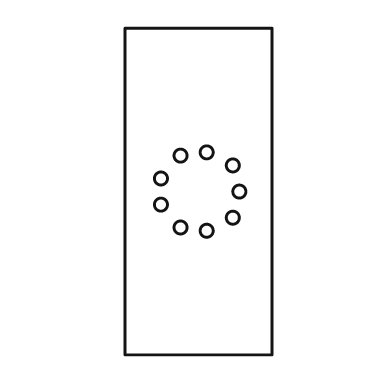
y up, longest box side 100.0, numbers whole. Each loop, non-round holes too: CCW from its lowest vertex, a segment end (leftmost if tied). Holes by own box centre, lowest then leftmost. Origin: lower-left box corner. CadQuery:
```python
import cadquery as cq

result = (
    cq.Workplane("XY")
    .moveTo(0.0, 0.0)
    .lineTo(45.0, 0.0)
    .lineTo(45.0, 100.0)
    .lineTo(0.0, 100.0)
    .close()
    .moveTo(25.0, 38.0)
    .circle(2.0)
    .moveTo(17.0, 39.0)
    .circle(2.0)
    .moveTo(33.0, 42.0)
    .circle(2.0)
    .moveTo(11.0, 46.0)
    .circle(2.0)
    .moveTo(35.0, 50.0)
    .circle(2.0)
    .moveTo(11.0, 54.0)
    .circle(2.0)
    .moveTo(33.0, 58.0)
    .circle(2.0)
    .moveTo(17.0, 61.0)
    .circle(2.0)
    .moveTo(25.0, 62.0)
    .circle(2.0)
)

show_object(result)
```